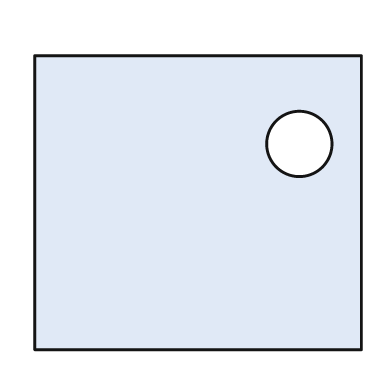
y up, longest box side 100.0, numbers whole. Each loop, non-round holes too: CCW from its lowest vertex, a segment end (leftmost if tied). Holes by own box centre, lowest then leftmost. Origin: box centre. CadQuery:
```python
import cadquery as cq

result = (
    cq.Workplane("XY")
    .moveTo(-50.0, -45.0)
    .lineTo(50.0, -45.0)
    .lineTo(50.0, 45.0)
    .lineTo(-50.0, 45.0)
    .close()
    .moveTo(31.0, 18.0)
    .circle(10.0)
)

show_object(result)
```